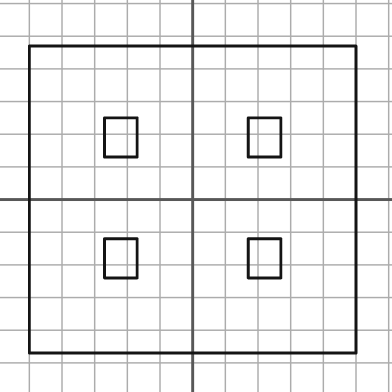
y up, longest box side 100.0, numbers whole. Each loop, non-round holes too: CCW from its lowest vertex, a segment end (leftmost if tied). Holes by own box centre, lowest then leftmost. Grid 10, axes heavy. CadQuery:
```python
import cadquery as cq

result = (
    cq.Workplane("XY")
    .moveTo(-50.0, -47.0)
    .lineTo(50.0, -47.0)
    .lineTo(50.0, 47.0)
    .lineTo(-50.0, 47.0)
    .close()
    .moveTo(-27.0, -24.0)
    .lineTo(-17.0, -24.0)
    .lineTo(-17.0, -12.0)
    .lineTo(-27.0, -12.0)
    .close()
    .moveTo(17.0, -24.0)
    .lineTo(27.0, -24.0)
    .lineTo(27.0, -12.0)
    .lineTo(17.0, -12.0)
    .close()
    .moveTo(-27.0, 13.0)
    .lineTo(-17.0, 13.0)
    .lineTo(-17.0, 25.0)
    .lineTo(-27.0, 25.0)
    .close()
    .moveTo(17.0, 13.0)
    .lineTo(27.0, 13.0)
    .lineTo(27.0, 25.0)
    .lineTo(17.0, 25.0)
    .close()
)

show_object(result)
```